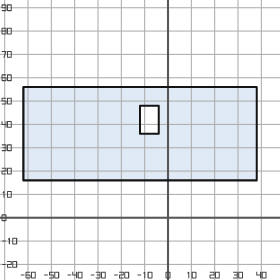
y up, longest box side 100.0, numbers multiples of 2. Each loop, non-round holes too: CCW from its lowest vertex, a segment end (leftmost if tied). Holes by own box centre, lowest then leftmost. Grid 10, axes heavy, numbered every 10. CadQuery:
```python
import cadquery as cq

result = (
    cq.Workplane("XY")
    .moveTo(-62.0, 16.0)
    .lineTo(38.0, 16.0)
    .lineTo(38.0, 56.0)
    .lineTo(-62.0, 56.0)
    .close()
    .moveTo(-12.0, 36.0)
    .lineTo(-4.0, 36.0)
    .lineTo(-4.0, 48.0)
    .lineTo(-12.0, 48.0)
    .close()
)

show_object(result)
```